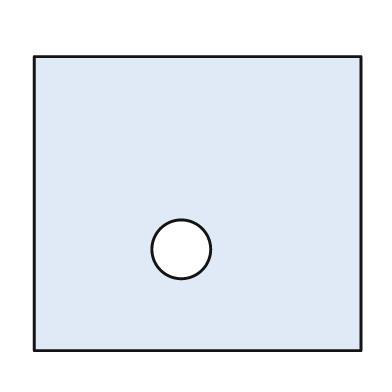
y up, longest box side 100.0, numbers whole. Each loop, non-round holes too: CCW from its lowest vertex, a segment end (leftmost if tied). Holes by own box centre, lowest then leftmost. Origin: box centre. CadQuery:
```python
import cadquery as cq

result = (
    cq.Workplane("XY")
    .moveTo(-50.0, -45.0)
    .lineTo(50.0, -45.0)
    .lineTo(50.0, 45.0)
    .lineTo(-50.0, 45.0)
    .close()
    .moveTo(-5.0, -14.0)
    .circle(9.0)
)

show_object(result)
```